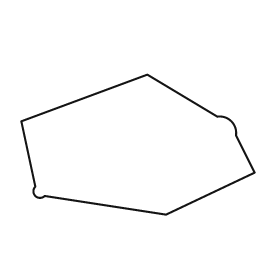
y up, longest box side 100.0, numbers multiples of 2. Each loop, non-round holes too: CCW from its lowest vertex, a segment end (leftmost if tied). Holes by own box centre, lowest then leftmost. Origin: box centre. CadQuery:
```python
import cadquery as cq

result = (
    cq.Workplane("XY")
    .moveTo(12.0, -30.0)
    .lineTo(50.0, -12.0)
    .lineTo(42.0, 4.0)
    .threePointArc((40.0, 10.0), (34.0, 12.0))
    .lineTo(4.0, 30.0)
    .lineTo(-50.0, 10.0)
    .lineTo(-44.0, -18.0)
    .threePointArc((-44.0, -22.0), (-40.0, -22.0))
    .close()
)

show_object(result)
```